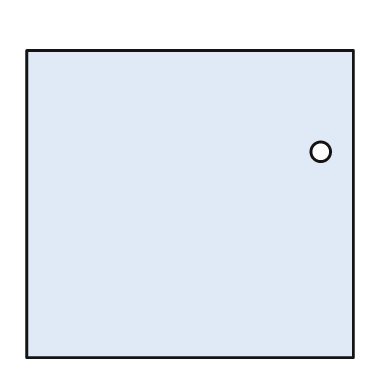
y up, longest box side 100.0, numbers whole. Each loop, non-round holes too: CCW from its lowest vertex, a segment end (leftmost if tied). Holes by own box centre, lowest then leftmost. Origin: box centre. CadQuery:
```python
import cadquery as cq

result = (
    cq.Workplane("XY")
    .moveTo(-50.0, -47.0)
    .lineTo(50.0, -47.0)
    .lineTo(50.0, 47.0)
    .lineTo(-50.0, 47.0)
    .close()
    .moveTo(40.0, 16.0)
    .circle(3.0)
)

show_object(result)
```